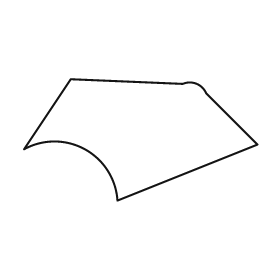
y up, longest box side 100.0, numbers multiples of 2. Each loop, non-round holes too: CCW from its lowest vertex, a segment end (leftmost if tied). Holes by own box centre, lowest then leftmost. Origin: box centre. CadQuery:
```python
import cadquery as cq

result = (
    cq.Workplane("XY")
    .moveTo(-10.0, -26.0)
    .lineTo(50.0, -2.0)
    .lineTo(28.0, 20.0)
    .threePointArc((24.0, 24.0), (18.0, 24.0))
    .lineTo(-30.0, 26.0)
    .lineTo(-50.0, -4.0)
    .threePointArc((-24.0, -4.0), (-10.0, -26.0))
    .close()
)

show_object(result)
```